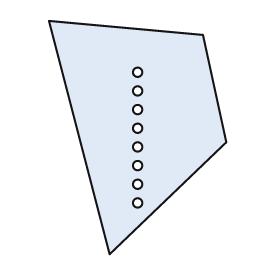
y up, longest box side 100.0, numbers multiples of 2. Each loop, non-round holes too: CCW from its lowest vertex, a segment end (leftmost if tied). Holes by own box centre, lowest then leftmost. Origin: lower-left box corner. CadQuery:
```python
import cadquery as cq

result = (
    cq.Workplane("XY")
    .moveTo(26.0, 0.0)
    .lineTo(76.0, 48.0)
    .lineTo(66.0, 94.0)
    .lineTo(0.0, 100.0)
    .close()
    .moveTo(38.0, 22.0)
    .circle(2.0)
    .moveTo(38.0, 30.0)
    .circle(2.0)
    .moveTo(38.0, 38.0)
    .circle(2.0)
    .moveTo(38.0, 46.0)
    .circle(2.0)
    .moveTo(38.0, 54.0)
    .circle(2.0)
    .moveTo(38.0, 62.0)
    .circle(2.0)
    .moveTo(38.0, 70.0)
    .circle(2.0)
    .moveTo(38.0, 78.0)
    .circle(2.0)
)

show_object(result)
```